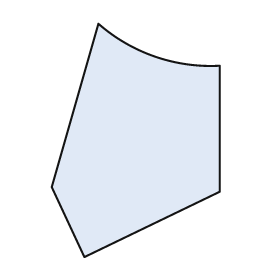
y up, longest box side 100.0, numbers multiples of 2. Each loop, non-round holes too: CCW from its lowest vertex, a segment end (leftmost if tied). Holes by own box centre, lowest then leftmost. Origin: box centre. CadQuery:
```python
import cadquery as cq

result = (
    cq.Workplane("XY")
    .moveTo(-22.0, -50.0)
    .lineTo(36.0, -22.0)
    .lineTo(36.0, 32.0)
    .threePointArc((8.0, 36.0), (-16.0, 50.0))
    .lineTo(-36.0, -20.0)
    .close()
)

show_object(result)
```